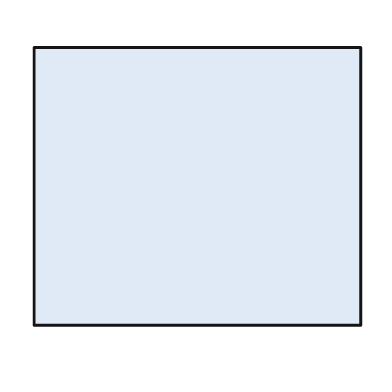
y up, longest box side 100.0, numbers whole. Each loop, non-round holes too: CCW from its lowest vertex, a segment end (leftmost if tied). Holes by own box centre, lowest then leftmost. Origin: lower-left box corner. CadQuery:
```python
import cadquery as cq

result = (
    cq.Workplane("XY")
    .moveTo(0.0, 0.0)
    .lineTo(100.0, 0.0)
    .lineTo(100.0, 85.0)
    .lineTo(0.0, 85.0)
    .close()
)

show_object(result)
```